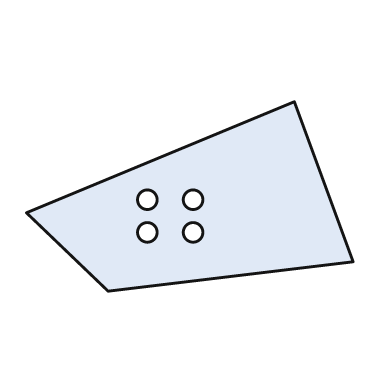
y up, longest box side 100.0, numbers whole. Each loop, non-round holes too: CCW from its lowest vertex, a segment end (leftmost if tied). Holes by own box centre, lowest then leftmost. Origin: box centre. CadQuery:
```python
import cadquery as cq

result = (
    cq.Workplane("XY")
    .moveTo(-25.0, -29.0)
    .lineTo(50.0, -20.0)
    .lineTo(32.0, 29.0)
    .lineTo(-50.0, -5.0)
    .close()
    .moveTo(-13.0, -11.0)
    .circle(3.0)
    .moveTo(1.0, -11.0)
    .circle(3.0)
    .moveTo(-13.0, -1.0)
    .circle(3.0)
    .moveTo(1.0, -1.0)
    .circle(3.0)
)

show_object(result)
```